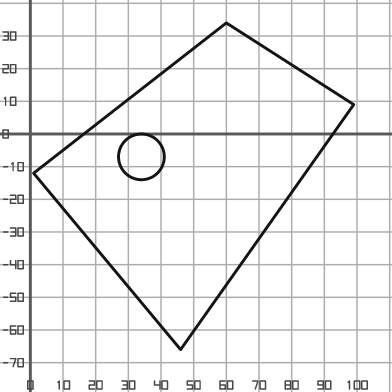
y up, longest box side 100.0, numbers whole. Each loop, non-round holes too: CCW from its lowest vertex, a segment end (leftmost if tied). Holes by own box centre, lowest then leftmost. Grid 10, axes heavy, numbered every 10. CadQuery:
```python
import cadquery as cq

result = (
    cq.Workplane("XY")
    .moveTo(46.0, -66.0)
    .lineTo(99.0, 9.0)
    .lineTo(60.0, 34.0)
    .lineTo(1.0, -12.0)
    .close()
    .moveTo(34.0, -7.0)
    .circle(7.0)
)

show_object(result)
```